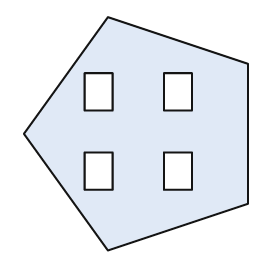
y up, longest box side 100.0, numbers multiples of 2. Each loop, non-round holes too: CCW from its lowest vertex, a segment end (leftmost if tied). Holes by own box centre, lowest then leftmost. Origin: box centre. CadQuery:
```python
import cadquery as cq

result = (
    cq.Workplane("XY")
    .moveTo(-12.0, -50.0)
    .lineTo(48.0, -30.0)
    .lineTo(48.0, 30.0)
    .lineTo(-12.0, 50.0)
    .lineTo(-48.0, 0.0)
    .close()
    .moveTo(-22.0, -24.0)
    .lineTo(-10.0, -24.0)
    .lineTo(-10.0, -8.0)
    .lineTo(-22.0, -8.0)
    .close()
    .moveTo(12.0, -24.0)
    .lineTo(24.0, -24.0)
    .lineTo(24.0, -8.0)
    .lineTo(12.0, -8.0)
    .close()
    .moveTo(-22.0, 10.0)
    .lineTo(-10.0, 10.0)
    .lineTo(-10.0, 26.0)
    .lineTo(-22.0, 26.0)
    .close()
    .moveTo(12.0, 10.0)
    .lineTo(24.0, 10.0)
    .lineTo(24.0, 26.0)
    .lineTo(12.0, 26.0)
    .close()
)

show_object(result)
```